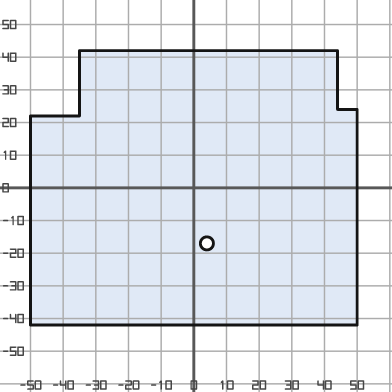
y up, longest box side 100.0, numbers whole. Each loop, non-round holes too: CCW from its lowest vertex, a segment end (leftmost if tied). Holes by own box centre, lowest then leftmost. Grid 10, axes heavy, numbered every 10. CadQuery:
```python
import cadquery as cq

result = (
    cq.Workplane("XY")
    .moveTo(-50.0, -42.0)
    .lineTo(50.0, -42.0)
    .lineTo(50.0, 24.0)
    .lineTo(44.0, 24.0)
    .lineTo(44.0, 42.0)
    .lineTo(-35.0, 42.0)
    .lineTo(-35.0, 22.0)
    .lineTo(-50.0, 22.0)
    .close()
    .moveTo(4.0, -17.0)
    .circle(2.0)
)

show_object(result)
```